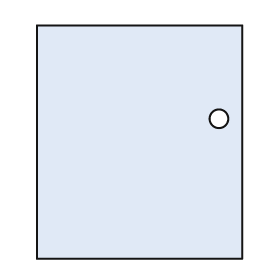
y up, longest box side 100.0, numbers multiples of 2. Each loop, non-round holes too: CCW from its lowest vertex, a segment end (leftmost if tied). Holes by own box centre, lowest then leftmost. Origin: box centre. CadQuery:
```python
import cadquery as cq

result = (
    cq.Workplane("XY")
    .moveTo(-44.0, -50.0)
    .lineTo(44.0, -50.0)
    .lineTo(44.0, 50.0)
    .lineTo(-44.0, 50.0)
    .close()
    .moveTo(34.0, 10.0)
    .circle(4.0)
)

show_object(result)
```